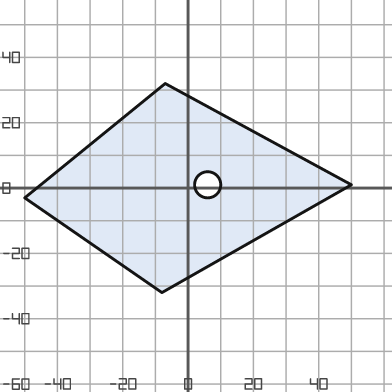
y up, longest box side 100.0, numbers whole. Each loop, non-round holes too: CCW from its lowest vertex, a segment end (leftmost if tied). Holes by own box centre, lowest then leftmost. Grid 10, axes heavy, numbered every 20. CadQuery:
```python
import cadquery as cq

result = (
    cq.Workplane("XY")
    .moveTo(-8.0, -32.0)
    .lineTo(50.0, 1.0)
    .lineTo(-7.0, 32.0)
    .lineTo(-50.0, -3.0)
    .close()
    .moveTo(6.0, 1.0)
    .circle(4.0)
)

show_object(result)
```